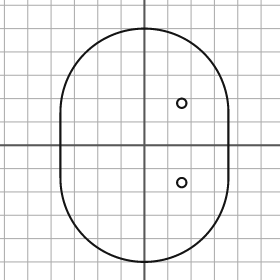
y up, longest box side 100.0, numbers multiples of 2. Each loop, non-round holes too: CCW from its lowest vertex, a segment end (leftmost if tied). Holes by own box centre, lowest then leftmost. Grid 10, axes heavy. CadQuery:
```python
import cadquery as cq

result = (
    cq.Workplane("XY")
    .moveTo(-36.0, -14.0)
    .threePointArc((0.0, -50.0), (36.0, -14.0))
    .lineTo(36.0, 14.0)
    .threePointArc((0.0, 50.0), (-36.0, 14.0))
    .close()
    .moveTo(16.0, -16.0)
    .circle(2.0)
    .moveTo(16.0, 18.0)
    .circle(2.0)
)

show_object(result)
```